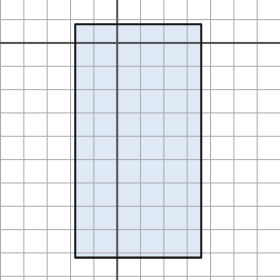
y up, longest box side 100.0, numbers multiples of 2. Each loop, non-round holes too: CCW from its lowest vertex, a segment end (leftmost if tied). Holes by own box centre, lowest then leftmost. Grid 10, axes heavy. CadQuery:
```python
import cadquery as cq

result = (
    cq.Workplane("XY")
    .moveTo(-18.0, -92.0)
    .lineTo(36.0, -92.0)
    .lineTo(36.0, 8.0)
    .lineTo(-18.0, 8.0)
    .close()
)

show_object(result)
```